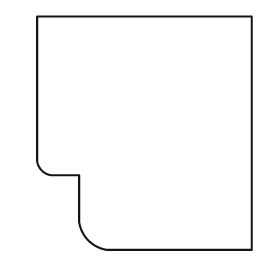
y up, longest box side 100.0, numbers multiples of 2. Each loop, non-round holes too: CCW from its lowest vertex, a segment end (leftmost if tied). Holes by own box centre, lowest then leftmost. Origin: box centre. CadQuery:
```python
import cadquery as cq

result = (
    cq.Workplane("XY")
    .moveTo(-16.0, -50.0)
    .lineTo(46.0, -50.0)
    .lineTo(46.0, 50.0)
    .lineTo(-46.0, 50.0)
    .lineTo(-46.0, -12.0)
    .threePointArc((-44.0, -16.0), (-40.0, -18.0))
    .lineTo(-28.0, -18.0)
    .lineTo(-28.0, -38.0)
    .threePointArc((-24.0, -46.0), (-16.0, -50.0))
    .close()
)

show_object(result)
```